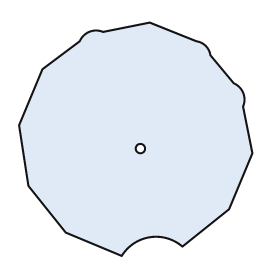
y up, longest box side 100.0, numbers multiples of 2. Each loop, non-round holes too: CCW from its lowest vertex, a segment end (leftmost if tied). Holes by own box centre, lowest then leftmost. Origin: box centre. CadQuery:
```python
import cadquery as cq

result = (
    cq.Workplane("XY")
    .moveTo(-6.0, -50.0)
    .threePointArc((6.0, -42.0), (20.0, -46.0))
    .lineTo(40.0, -30.0)
    .lineTo(50.0, -6.0)
    .lineTo(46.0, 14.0)
    .threePointArc((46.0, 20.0), (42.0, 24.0))
    .lineTo(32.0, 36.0)
    .threePointArc((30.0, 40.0), (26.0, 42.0))
    .lineTo(6.0, 50.0)
    .lineTo(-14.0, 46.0)
    .threePointArc((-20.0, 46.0), (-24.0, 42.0))
    .lineTo(-40.0, 30.0)
    .lineTo(-50.0, 6.0)
    .lineTo(-46.0, -20.0)
    .lineTo(-30.0, -40.0)
    .close()
    .moveTo(2.0, -4.0)
    .circle(2.0)
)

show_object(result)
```